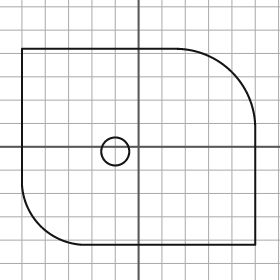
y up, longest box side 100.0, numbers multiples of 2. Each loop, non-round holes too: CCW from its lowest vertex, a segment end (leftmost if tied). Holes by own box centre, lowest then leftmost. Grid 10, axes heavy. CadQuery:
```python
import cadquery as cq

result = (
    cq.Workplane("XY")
    .moveTo(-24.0, -42.0)
    .lineTo(50.0, -42.0)
    .lineTo(50.0, 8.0)
    .threePointArc((40.0, 32.0), (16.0, 42.0))
    .lineTo(-50.0, 42.0)
    .lineTo(-50.0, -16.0)
    .threePointArc((-42.0, -34.0), (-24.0, -42.0))
    .close()
    .moveTo(-10.0, -2.0)
    .circle(6.0)
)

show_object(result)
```